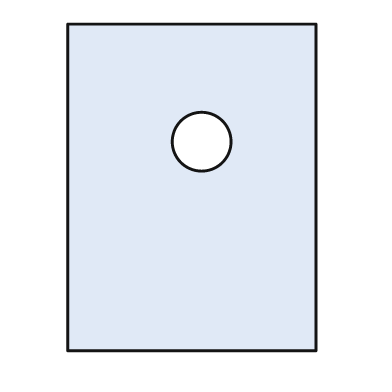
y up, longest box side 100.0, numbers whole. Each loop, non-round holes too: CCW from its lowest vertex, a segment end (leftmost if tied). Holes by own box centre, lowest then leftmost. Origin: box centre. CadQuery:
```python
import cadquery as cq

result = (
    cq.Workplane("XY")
    .moveTo(-38.0, -50.0)
    .lineTo(38.0, -50.0)
    .lineTo(38.0, 50.0)
    .lineTo(-38.0, 50.0)
    .close()
    .moveTo(3.0, 14.0)
    .circle(9.0)
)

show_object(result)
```